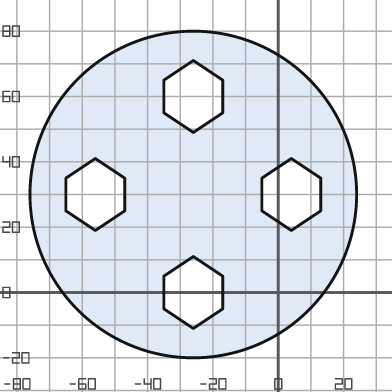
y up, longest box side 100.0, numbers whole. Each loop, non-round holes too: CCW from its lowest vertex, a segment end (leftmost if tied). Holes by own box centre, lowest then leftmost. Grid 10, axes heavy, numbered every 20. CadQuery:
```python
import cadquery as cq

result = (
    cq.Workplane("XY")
    .moveTo(-26.0, 30.0)
    .circle(50.0)
    .moveTo(-26.0, -11.0)
    .lineTo(-17.0, -5.0)
    .lineTo(-17.0, 5.0)
    .lineTo(-26.0, 11.0)
    .lineTo(-35.0, 5.0)
    .lineTo(-35.0, -5.0)
    .close()
    .moveTo(-56.0, 19.0)
    .lineTo(-47.0, 25.0)
    .lineTo(-47.0, 35.0)
    .lineTo(-56.0, 41.0)
    .lineTo(-65.0, 35.0)
    .lineTo(-65.0, 25.0)
    .close()
    .moveTo(4.0, 19.0)
    .lineTo(13.0, 25.0)
    .lineTo(13.0, 35.0)
    .lineTo(4.0, 41.0)
    .lineTo(-5.0, 35.0)
    .lineTo(-5.0, 25.0)
    .close()
    .moveTo(-26.0, 49.0)
    .lineTo(-17.0, 55.0)
    .lineTo(-17.0, 65.0)
    .lineTo(-26.0, 71.0)
    .lineTo(-35.0, 65.0)
    .lineTo(-35.0, 55.0)
    .close()
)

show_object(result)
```